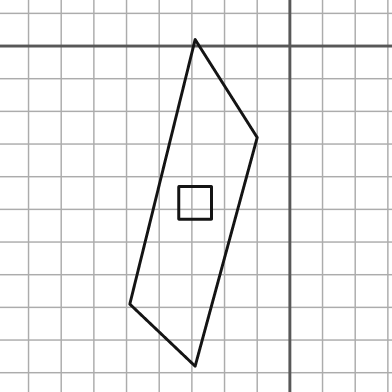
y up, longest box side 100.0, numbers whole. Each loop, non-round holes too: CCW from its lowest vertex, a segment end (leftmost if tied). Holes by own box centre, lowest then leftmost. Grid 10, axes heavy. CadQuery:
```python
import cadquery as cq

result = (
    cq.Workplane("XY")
    .moveTo(-29.0, -98.0)
    .lineTo(-10.0, -28.0)
    .lineTo(-29.0, 2.0)
    .lineTo(-49.0, -79.0)
    .close()
    .moveTo(-34.0, -53.0)
    .lineTo(-24.0, -53.0)
    .lineTo(-24.0, -43.0)
    .lineTo(-34.0, -43.0)
    .close()
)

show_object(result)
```